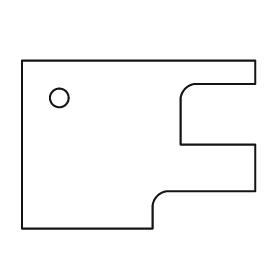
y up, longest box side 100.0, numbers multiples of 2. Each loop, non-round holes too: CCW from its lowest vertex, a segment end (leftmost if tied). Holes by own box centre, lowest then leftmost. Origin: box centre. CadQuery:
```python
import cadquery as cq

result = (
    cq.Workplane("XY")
    .moveTo(-50.0, -36.0)
    .lineTo(6.0, -36.0)
    .lineTo(6.0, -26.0)
    .threePointArc((8.0, -22.0), (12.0, -20.0))
    .lineTo(50.0, -20.0)
    .lineTo(50.0, 0.0)
    .lineTo(18.0, 0.0)
    .lineTo(18.0, 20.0)
    .threePointArc((20.0, 24.0), (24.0, 26.0))
    .lineTo(50.0, 26.0)
    .lineTo(50.0, 36.0)
    .lineTo(-50.0, 36.0)
    .close()
    .moveTo(-34.0, 20.0)
    .circle(4.0)
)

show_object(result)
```